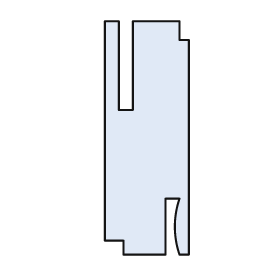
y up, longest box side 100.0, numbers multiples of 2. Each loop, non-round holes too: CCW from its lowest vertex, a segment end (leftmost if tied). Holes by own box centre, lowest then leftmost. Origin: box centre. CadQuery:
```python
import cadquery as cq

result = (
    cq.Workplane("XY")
    .moveTo(-10.0, -50.0)
    .lineTo(8.0, -50.0)
    .lineTo(8.0, -26.0)
    .lineTo(14.0, -26.0)
    .threePointArc((12.0, -38.0), (14.0, -50.0))
    .lineTo(18.0, -50.0)
    .lineTo(18.0, 42.0)
    .lineTo(14.0, 42.0)
    .lineTo(14.0, 50.0)
    .lineTo(-6.0, 50.0)
    .lineTo(-6.0, 12.0)
    .lineTo(-12.0, 12.0)
    .lineTo(-12.0, 50.0)
    .lineTo(-18.0, 50.0)
    .lineTo(-18.0, -44.0)
    .lineTo(-10.0, -44.0)
    .close()
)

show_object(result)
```